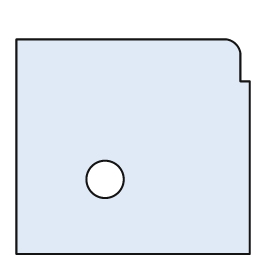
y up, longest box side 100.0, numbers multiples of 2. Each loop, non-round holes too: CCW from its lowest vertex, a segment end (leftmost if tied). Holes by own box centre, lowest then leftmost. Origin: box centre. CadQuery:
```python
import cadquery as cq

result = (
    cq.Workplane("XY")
    .moveTo(-50.0, -46.0)
    .lineTo(50.0, -46.0)
    .lineTo(50.0, 28.0)
    .lineTo(46.0, 28.0)
    .lineTo(46.0, 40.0)
    .threePointArc((44.0, 44.0), (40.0, 46.0))
    .lineTo(-50.0, 46.0)
    .close()
    .moveTo(-12.0, -14.0)
    .circle(8.0)
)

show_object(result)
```